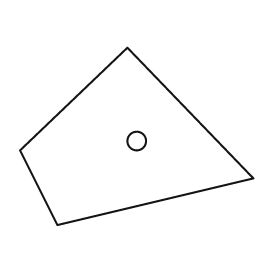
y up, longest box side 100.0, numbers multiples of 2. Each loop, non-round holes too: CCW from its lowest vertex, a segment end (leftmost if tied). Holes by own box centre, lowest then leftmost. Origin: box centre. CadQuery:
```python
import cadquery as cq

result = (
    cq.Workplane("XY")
    .moveTo(-34.0, -38.0)
    .lineTo(50.0, -18.0)
    .lineTo(-4.0, 38.0)
    .lineTo(-50.0, -6.0)
    .close()
    .moveTo(0.0, -2.0)
    .circle(4.0)
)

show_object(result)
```